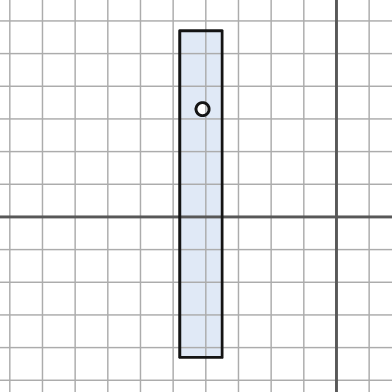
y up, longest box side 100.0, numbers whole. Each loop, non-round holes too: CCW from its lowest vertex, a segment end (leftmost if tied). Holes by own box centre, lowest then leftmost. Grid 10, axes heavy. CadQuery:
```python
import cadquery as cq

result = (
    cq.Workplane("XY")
    .moveTo(-48.0, -43.0)
    .lineTo(-35.0, -43.0)
    .lineTo(-35.0, 57.0)
    .lineTo(-48.0, 57.0)
    .close()
    .moveTo(-41.0, 33.0)
    .circle(2.0)
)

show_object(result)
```